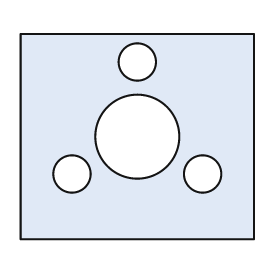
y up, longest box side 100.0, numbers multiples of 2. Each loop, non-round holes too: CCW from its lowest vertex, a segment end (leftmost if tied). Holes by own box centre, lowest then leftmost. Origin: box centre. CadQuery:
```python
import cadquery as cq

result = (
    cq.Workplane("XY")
    .moveTo(-50.0, -44.0)
    .lineTo(50.0, -44.0)
    .lineTo(50.0, 44.0)
    .lineTo(-50.0, 44.0)
    .close()
    .moveTo(-28.0, -16.0)
    .circle(8.0)
    .moveTo(28.0, -16.0)
    .circle(8.0)
    .moveTo(0.0, 0.0)
    .circle(18.0)
    .moveTo(0.0, 32.0)
    .circle(8.0)
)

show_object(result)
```